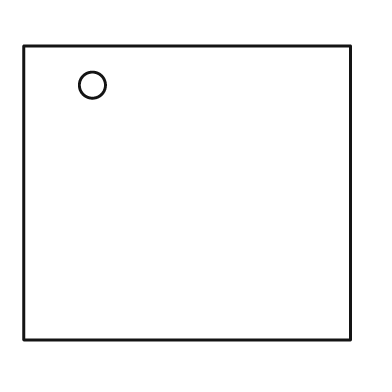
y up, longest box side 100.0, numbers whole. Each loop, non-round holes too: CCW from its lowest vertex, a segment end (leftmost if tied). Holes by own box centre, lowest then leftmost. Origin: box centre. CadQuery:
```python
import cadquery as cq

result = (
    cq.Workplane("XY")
    .moveTo(-50.0, -45.0)
    .lineTo(50.0, -45.0)
    .lineTo(50.0, 45.0)
    .lineTo(-50.0, 45.0)
    .close()
    .moveTo(-29.0, 33.0)
    .circle(4.0)
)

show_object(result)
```